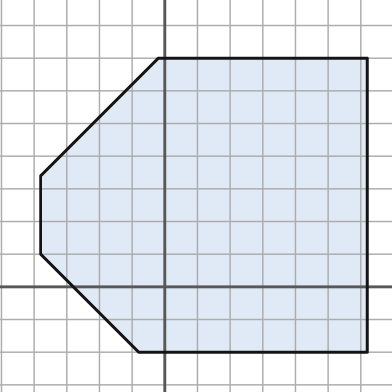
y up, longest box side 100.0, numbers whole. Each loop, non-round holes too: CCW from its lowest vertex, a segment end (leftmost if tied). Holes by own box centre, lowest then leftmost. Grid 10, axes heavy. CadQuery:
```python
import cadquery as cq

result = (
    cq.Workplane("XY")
    .moveTo(-8.0, -20.0)
    .lineTo(62.0, -20.0)
    .lineTo(62.0, 70.0)
    .lineTo(-2.0, 70.0)
    .lineTo(-38.0, 34.0)
    .lineTo(-38.0, 10.0)
    .close()
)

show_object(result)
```